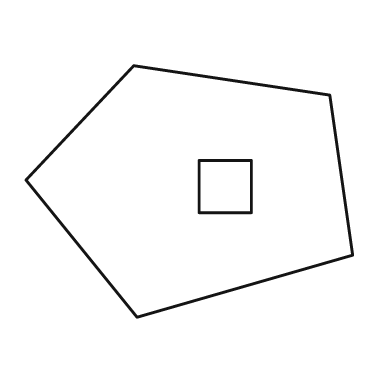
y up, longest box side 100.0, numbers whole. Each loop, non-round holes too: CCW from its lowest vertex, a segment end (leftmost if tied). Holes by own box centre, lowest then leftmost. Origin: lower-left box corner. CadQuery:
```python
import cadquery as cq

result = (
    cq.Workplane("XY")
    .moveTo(34.0, 0.0)
    .lineTo(100.0, 19.0)
    .lineTo(93.0, 68.0)
    .lineTo(33.0, 77.0)
    .lineTo(0.0, 42.0)
    .close()
    .moveTo(53.0, 32.0)
    .lineTo(69.0, 32.0)
    .lineTo(69.0, 48.0)
    .lineTo(53.0, 48.0)
    .close()
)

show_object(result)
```